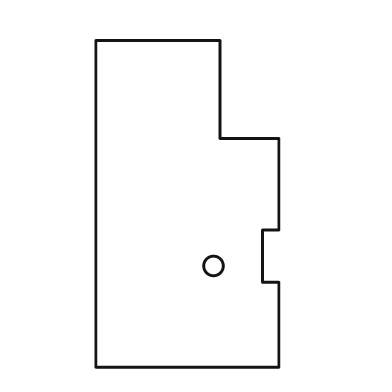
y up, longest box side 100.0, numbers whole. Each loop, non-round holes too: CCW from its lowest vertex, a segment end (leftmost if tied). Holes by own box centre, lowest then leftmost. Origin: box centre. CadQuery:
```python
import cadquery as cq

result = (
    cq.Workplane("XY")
    .moveTo(-28.0, -50.0)
    .lineTo(28.0, -50.0)
    .lineTo(28.0, -24.0)
    .lineTo(23.0, -24.0)
    .lineTo(23.0, -8.0)
    .lineTo(28.0, -8.0)
    .lineTo(28.0, 20.0)
    .lineTo(10.0, 20.0)
    .lineTo(10.0, 50.0)
    .lineTo(-28.0, 50.0)
    .close()
    .moveTo(8.0, -19.0)
    .circle(3.0)
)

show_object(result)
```